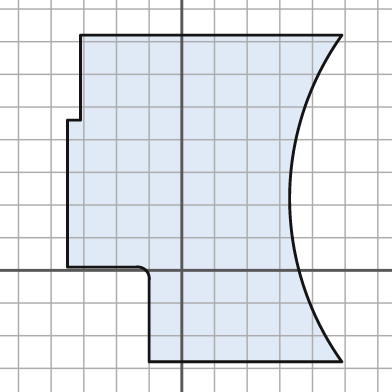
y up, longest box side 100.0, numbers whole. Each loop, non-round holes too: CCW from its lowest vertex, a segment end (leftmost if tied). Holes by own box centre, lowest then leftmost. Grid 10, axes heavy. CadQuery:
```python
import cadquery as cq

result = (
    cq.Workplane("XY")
    .moveTo(-10.0, -28.0)
    .lineTo(49.0, -28.0)
    .threePointArc((33.0, 22.0), (49.0, 72.0))
    .lineTo(-31.0, 72.0)
    .lineTo(-31.0, 46.0)
    .lineTo(-35.0, 46.0)
    .lineTo(-35.0, 1.0)
    .lineTo(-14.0, 1.0)
    .threePointArc((-11.0, 0.0), (-10.0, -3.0))
    .close()
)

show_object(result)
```